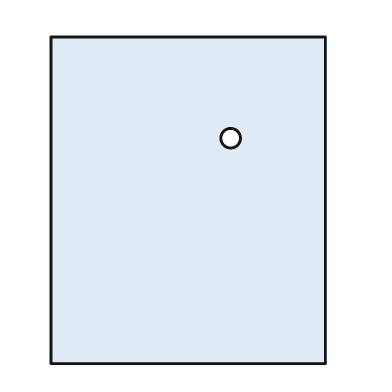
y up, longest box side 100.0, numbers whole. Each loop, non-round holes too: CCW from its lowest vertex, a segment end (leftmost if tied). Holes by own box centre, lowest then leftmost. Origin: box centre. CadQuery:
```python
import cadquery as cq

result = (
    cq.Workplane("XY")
    .moveTo(-42.0, -50.0)
    .lineTo(42.0, -50.0)
    .lineTo(42.0, 50.0)
    .lineTo(-42.0, 50.0)
    .close()
    .moveTo(13.0, 19.0)
    .circle(3.0)
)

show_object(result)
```